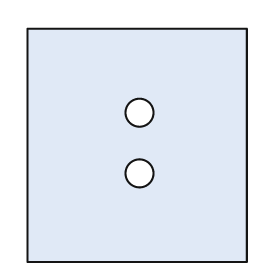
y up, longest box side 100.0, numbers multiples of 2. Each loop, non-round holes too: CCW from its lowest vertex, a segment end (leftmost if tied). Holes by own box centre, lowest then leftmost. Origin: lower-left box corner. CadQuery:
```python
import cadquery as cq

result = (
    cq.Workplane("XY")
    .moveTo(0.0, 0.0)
    .lineTo(94.0, 0.0)
    .lineTo(94.0, 100.0)
    .lineTo(0.0, 100.0)
    .close()
    .moveTo(48.0, 38.0)
    .circle(6.0)
    .moveTo(48.0, 64.0)
    .circle(6.0)
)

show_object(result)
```